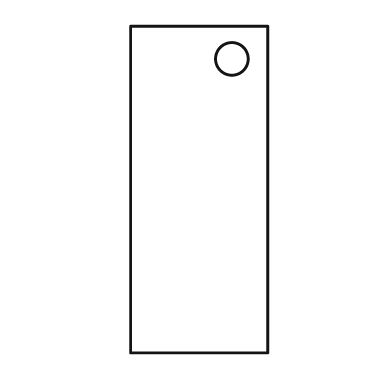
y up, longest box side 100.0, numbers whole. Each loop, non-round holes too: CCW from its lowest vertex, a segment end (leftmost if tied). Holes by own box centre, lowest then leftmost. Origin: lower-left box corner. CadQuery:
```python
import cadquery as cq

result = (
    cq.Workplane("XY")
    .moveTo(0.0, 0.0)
    .lineTo(42.0, 0.0)
    .lineTo(42.0, 100.0)
    .lineTo(0.0, 100.0)
    .close()
    .moveTo(31.0, 90.0)
    .circle(5.0)
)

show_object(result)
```